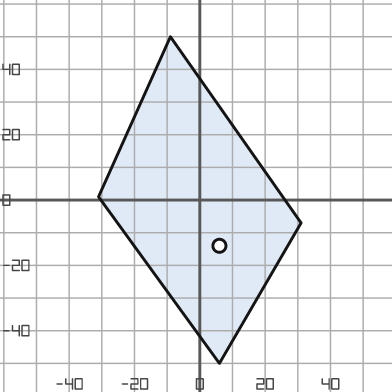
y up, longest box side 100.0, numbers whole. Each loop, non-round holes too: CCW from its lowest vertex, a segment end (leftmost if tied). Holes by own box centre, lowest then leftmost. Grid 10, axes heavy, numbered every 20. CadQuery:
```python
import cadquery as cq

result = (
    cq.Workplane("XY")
    .moveTo(6.0, -50.0)
    .lineTo(31.0, -7.0)
    .lineTo(-9.0, 50.0)
    .lineTo(-31.0, 1.0)
    .close()
    .moveTo(6.0, -14.0)
    .circle(2.0)
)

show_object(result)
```